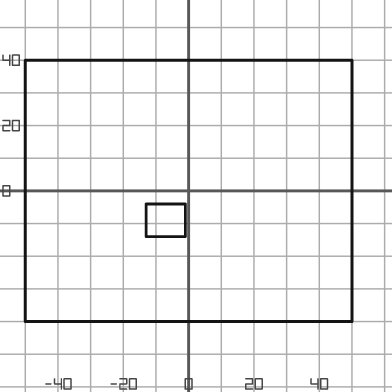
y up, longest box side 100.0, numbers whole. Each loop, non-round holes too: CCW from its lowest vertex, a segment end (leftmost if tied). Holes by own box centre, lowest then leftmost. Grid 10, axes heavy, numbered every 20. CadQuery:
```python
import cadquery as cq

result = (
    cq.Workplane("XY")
    .moveTo(-50.0, -40.0)
    .lineTo(50.0, -40.0)
    .lineTo(50.0, 40.0)
    .lineTo(-50.0, 40.0)
    .close()
    .moveTo(-13.0, -14.0)
    .lineTo(-1.0, -14.0)
    .lineTo(-1.0, -4.0)
    .lineTo(-13.0, -4.0)
    .close()
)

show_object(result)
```